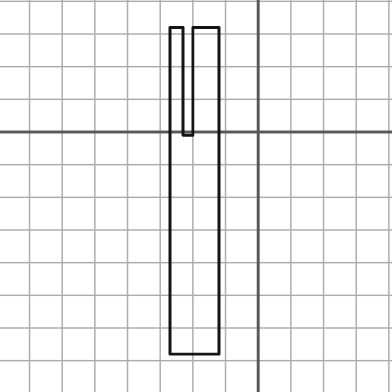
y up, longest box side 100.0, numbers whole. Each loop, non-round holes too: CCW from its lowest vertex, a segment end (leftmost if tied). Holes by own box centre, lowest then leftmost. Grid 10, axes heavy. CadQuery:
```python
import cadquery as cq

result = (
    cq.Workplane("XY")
    .moveTo(-27.0, -68.0)
    .lineTo(-12.0, -68.0)
    .lineTo(-12.0, 32.0)
    .lineTo(-20.0, 32.0)
    .lineTo(-20.0, -1.0)
    .lineTo(-23.0, -1.0)
    .lineTo(-23.0, 32.0)
    .lineTo(-27.0, 32.0)
    .close()
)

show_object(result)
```